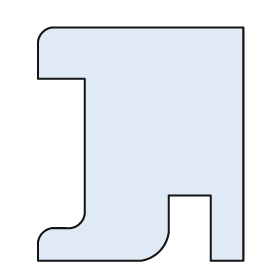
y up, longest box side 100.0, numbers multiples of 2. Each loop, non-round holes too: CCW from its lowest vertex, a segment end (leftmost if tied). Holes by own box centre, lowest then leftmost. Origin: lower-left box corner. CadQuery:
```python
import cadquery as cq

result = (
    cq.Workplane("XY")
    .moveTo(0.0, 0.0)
    .lineTo(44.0, 0.0)
    .threePointArc((52.0, 4.0), (56.0, 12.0))
    .lineTo(56.0, 28.0)
    .lineTo(74.0, 28.0)
    .lineTo(74.0, 0.0)
    .lineTo(88.0, 0.0)
    .lineTo(88.0, 100.0)
    .lineTo(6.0, 100.0)
    .threePointArc((2.0, 98.0), (0.0, 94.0))
    .lineTo(0.0, 78.0)
    .lineTo(20.0, 78.0)
    .lineTo(20.0, 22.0)
    .threePointArc((18.0, 16.0), (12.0, 14.0))
    .lineTo(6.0, 14.0)
    .threePointArc((2.0, 12.0), (0.0, 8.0))
    .close()
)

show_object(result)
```